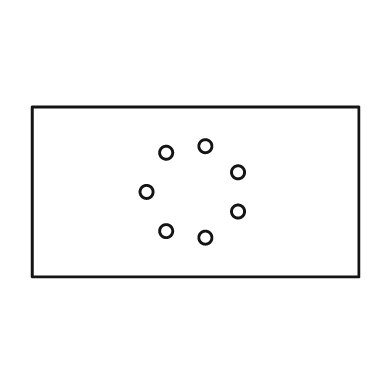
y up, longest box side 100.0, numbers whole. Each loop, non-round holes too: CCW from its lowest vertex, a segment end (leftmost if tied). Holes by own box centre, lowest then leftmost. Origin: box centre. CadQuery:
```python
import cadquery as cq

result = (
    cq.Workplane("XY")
    .moveTo(-50.0, -26.0)
    .lineTo(50.0, -26.0)
    .lineTo(50.0, 26.0)
    .lineTo(-50.0, 26.0)
    .close()
    .moveTo(3.0, -14.0)
    .circle(2.0)
    .moveTo(-9.0, -12.0)
    .circle(2.0)
    .moveTo(13.0, -6.0)
    .circle(2.0)
    .moveTo(-15.0, 0.0)
    .circle(2.0)
    .moveTo(13.0, 6.0)
    .circle(2.0)
    .moveTo(-9.0, 12.0)
    .circle(2.0)
    .moveTo(3.0, 14.0)
    .circle(2.0)
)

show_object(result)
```